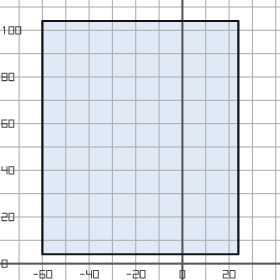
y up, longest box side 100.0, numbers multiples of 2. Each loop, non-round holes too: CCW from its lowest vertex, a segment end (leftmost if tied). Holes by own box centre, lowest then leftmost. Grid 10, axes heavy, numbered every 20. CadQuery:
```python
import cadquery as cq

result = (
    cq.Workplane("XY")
    .moveTo(-60.0, 4.0)
    .lineTo(24.0, 4.0)
    .lineTo(24.0, 104.0)
    .lineTo(-60.0, 104.0)
    .close()
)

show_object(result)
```